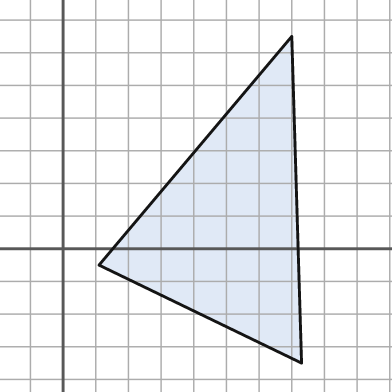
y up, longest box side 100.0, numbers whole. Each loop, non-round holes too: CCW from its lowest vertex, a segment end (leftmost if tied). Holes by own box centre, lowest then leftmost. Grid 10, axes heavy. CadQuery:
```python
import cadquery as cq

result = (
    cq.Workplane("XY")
    .moveTo(73.0, -35.0)
    .lineTo(70.0, 65.0)
    .lineTo(11.0, -5.0)
    .close()
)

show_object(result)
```